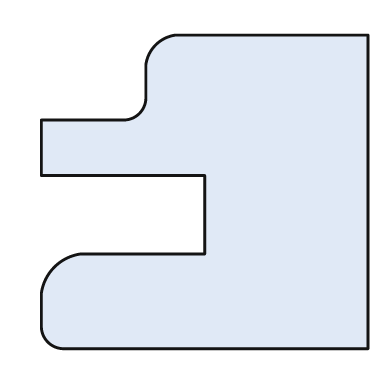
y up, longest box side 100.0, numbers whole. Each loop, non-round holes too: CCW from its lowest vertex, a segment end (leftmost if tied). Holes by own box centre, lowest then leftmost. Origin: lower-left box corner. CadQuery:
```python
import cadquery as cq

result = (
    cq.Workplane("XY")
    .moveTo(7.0, 0.0)
    .lineTo(100.0, 0.0)
    .lineTo(100.0, 96.0)
    .lineTo(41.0, 96.0)
    .threePointArc((35.0, 93.0), (32.0, 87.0))
    .lineTo(32.0, 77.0)
    .threePointArc((30.0, 72.0), (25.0, 70.0))
    .lineTo(0.0, 70.0)
    .lineTo(0.0, 53.0)
    .lineTo(50.0, 53.0)
    .lineTo(50.0, 29.0)
    .lineTo(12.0, 29.0)
    .threePointArc((4.0, 25.0), (0.0, 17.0))
    .lineTo(0.0, 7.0)
    .threePointArc((2.0, 2.0), (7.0, 0.0))
    .close()
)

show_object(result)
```